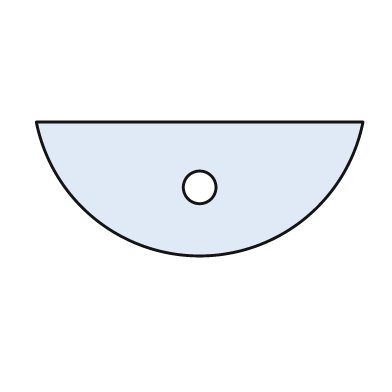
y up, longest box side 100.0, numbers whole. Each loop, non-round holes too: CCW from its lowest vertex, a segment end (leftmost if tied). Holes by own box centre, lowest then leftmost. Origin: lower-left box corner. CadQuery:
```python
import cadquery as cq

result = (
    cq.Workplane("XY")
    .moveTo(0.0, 41.0)
    .threePointArc((50.0, 0.0), (100.0, 41.0))
    .close()
    .moveTo(50.0, 21.0)
    .circle(5.0)
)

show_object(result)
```